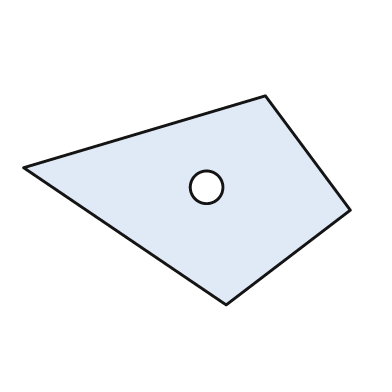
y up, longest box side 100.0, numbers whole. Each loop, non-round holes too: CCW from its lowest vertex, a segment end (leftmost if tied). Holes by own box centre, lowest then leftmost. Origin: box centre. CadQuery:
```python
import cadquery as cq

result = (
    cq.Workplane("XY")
    .moveTo(12.0, -32.0)
    .lineTo(50.0, -3.0)
    .lineTo(24.0, 32.0)
    .lineTo(-50.0, 10.0)
    .close()
    .moveTo(6.0, 4.0)
    .circle(5.0)
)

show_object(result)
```